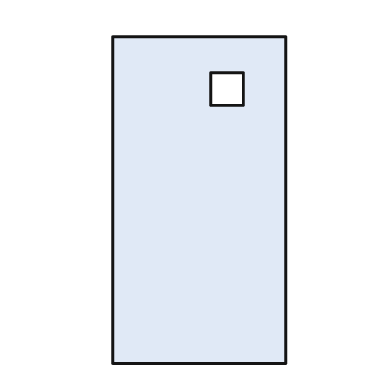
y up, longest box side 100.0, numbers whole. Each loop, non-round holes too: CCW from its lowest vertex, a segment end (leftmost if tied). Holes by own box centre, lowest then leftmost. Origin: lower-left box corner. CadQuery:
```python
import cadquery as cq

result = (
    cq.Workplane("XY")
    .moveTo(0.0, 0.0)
    .lineTo(53.0, 0.0)
    .lineTo(53.0, 100.0)
    .lineTo(0.0, 100.0)
    .close()
    .moveTo(30.0, 79.0)
    .lineTo(40.0, 79.0)
    .lineTo(40.0, 89.0)
    .lineTo(30.0, 89.0)
    .close()
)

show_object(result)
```